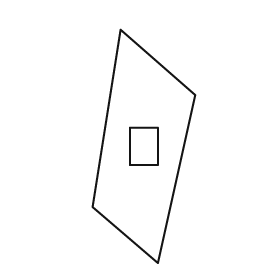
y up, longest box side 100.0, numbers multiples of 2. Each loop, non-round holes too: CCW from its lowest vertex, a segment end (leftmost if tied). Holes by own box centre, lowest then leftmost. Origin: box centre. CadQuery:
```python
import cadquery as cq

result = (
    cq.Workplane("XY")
    .moveTo(6.0, -50.0)
    .lineTo(22.0, 22.0)
    .lineTo(-10.0, 50.0)
    .lineTo(-22.0, -26.0)
    .close()
    .moveTo(-6.0, -8.0)
    .lineTo(6.0, -8.0)
    .lineTo(6.0, 8.0)
    .lineTo(-6.0, 8.0)
    .close()
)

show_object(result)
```